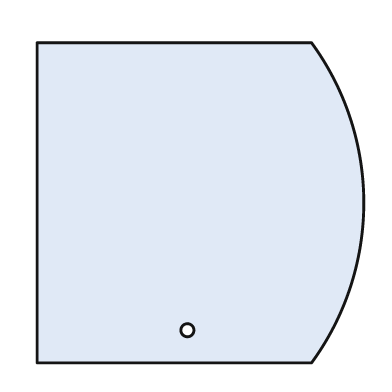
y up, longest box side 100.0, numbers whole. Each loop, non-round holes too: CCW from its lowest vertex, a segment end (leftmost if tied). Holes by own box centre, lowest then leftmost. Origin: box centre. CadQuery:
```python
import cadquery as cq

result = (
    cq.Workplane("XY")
    .moveTo(-50.0, -49.0)
    .lineTo(34.0, -49.0)
    .threePointArc((50.0, 0.0), (34.0, 49.0))
    .lineTo(-50.0, 49.0)
    .close()
    .moveTo(-4.0, -39.0)
    .circle(2.0)
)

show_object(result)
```